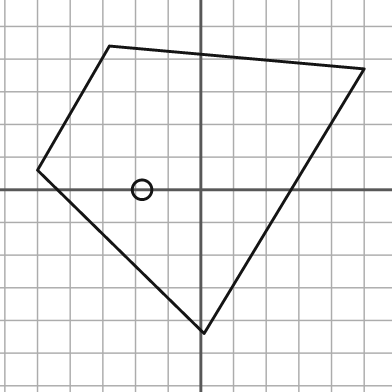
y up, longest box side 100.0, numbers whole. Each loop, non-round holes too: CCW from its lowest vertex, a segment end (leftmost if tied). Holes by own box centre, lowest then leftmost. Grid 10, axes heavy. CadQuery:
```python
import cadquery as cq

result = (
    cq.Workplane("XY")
    .moveTo(1.0, -44.0)
    .lineTo(50.0, 37.0)
    .lineTo(-28.0, 44.0)
    .lineTo(-50.0, 6.0)
    .close()
    .moveTo(-18.0, 0.0)
    .circle(3.0)
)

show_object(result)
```